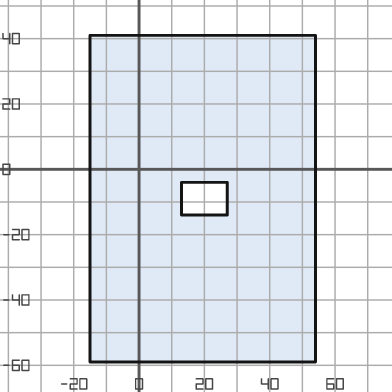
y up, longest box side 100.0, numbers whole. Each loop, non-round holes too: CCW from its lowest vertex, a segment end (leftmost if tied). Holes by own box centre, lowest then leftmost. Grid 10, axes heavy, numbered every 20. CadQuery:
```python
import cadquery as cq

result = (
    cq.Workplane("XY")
    .moveTo(-15.0, -59.0)
    .lineTo(54.0, -59.0)
    .lineTo(54.0, 41.0)
    .lineTo(-15.0, 41.0)
    .close()
    .moveTo(13.0, -14.0)
    .lineTo(27.0, -14.0)
    .lineTo(27.0, -4.0)
    .lineTo(13.0, -4.0)
    .close()
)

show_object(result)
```